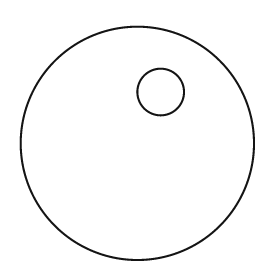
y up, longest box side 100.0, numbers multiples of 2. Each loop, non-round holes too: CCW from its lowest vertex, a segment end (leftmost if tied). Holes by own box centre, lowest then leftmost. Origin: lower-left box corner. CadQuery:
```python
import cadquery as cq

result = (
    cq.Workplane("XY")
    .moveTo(50.0, 50.0)
    .circle(50.0)
    .moveTo(60.0, 72.0)
    .circle(10.0)
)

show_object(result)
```